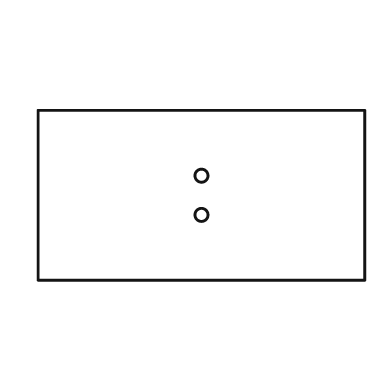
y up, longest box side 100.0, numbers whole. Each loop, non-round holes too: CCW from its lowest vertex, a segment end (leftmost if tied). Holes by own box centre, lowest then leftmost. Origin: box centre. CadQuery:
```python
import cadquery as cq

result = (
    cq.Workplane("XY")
    .moveTo(-50.0, -26.0)
    .lineTo(50.0, -26.0)
    .lineTo(50.0, 26.0)
    .lineTo(-50.0, 26.0)
    .close()
    .moveTo(0.0, -6.0)
    .circle(2.0)
    .moveTo(0.0, 6.0)
    .circle(2.0)
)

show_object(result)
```